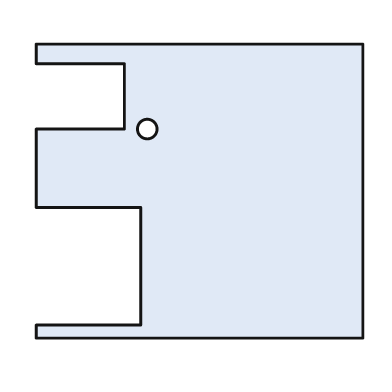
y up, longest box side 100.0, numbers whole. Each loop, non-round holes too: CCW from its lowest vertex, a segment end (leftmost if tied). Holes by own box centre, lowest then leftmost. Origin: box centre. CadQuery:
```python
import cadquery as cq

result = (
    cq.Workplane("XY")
    .moveTo(-50.0, -45.0)
    .lineTo(50.0, -45.0)
    .lineTo(50.0, 45.0)
    .lineTo(-50.0, 45.0)
    .lineTo(-50.0, 39.0)
    .lineTo(-23.0, 39.0)
    .lineTo(-23.0, 19.0)
    .lineTo(-50.0, 19.0)
    .lineTo(-50.0, -5.0)
    .lineTo(-18.0, -5.0)
    .lineTo(-18.0, -41.0)
    .lineTo(-50.0, -41.0)
    .close()
    .moveTo(-16.0, 19.0)
    .circle(3.0)
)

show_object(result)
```